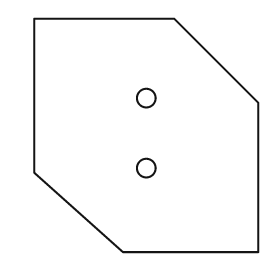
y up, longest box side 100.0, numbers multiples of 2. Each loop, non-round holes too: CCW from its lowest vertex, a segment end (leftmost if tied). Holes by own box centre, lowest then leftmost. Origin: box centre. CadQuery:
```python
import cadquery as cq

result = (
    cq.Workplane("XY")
    .moveTo(-10.0, -50.0)
    .lineTo(48.0, -50.0)
    .lineTo(48.0, 14.0)
    .lineTo(12.0, 50.0)
    .lineTo(-48.0, 50.0)
    .lineTo(-48.0, -16.0)
    .close()
    .moveTo(0.0, -14.0)
    .circle(4.0)
    .moveTo(0.0, 16.0)
    .circle(4.0)
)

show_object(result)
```